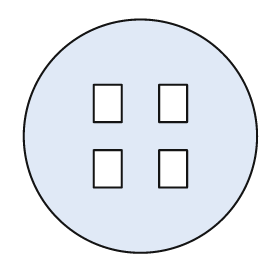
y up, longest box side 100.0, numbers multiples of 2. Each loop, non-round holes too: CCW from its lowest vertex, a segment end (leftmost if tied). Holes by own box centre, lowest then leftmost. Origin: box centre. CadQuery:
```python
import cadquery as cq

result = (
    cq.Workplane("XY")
    .moveTo(0.0, 0.0)
    .circle(50.0)
    .moveTo(-20.0, -22.0)
    .lineTo(-8.0, -22.0)
    .lineTo(-8.0, -6.0)
    .lineTo(-20.0, -6.0)
    .close()
    .moveTo(8.0, -22.0)
    .lineTo(20.0, -22.0)
    .lineTo(20.0, -6.0)
    .lineTo(8.0, -6.0)
    .close()
    .moveTo(-20.0, 6.0)
    .lineTo(-8.0, 6.0)
    .lineTo(-8.0, 22.0)
    .lineTo(-20.0, 22.0)
    .close()
    .moveTo(8.0, 6.0)
    .lineTo(20.0, 6.0)
    .lineTo(20.0, 22.0)
    .lineTo(8.0, 22.0)
    .close()
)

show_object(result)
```